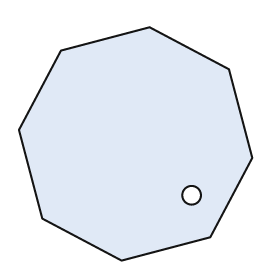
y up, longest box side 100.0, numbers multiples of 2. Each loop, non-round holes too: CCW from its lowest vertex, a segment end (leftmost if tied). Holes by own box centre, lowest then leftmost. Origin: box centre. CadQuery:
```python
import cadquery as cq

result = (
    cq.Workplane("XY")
    .moveTo(-6.0, -50.0)
    .lineTo(32.0, -40.0)
    .lineTo(50.0, -6.0)
    .lineTo(40.0, 32.0)
    .lineTo(6.0, 50.0)
    .lineTo(-32.0, 40.0)
    .lineTo(-50.0, 6.0)
    .lineTo(-40.0, -32.0)
    .close()
    .moveTo(24.0, -22.0)
    .circle(4.0)
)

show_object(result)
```